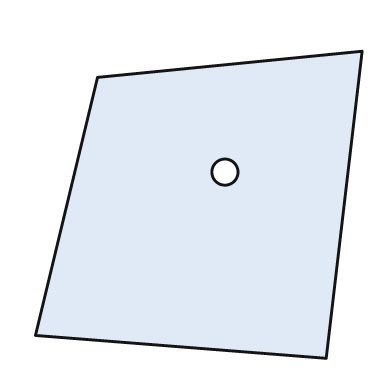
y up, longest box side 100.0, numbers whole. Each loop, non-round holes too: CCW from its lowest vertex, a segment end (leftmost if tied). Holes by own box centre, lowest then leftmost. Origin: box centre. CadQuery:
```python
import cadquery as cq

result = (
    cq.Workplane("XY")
    .moveTo(39.0, -47.0)
    .lineTo(50.0, 47.0)
    .lineTo(-31.0, 39.0)
    .lineTo(-50.0, -40.0)
    .close()
    .moveTo(8.0, 10.0)
    .circle(4.0)
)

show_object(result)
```